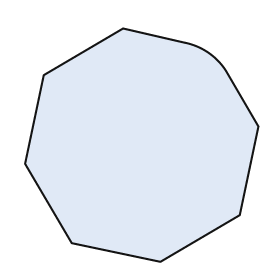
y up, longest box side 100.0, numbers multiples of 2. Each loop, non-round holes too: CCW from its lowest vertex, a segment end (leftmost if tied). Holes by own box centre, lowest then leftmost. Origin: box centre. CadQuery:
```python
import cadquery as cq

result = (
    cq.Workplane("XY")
    .moveTo(8.0, -50.0)
    .lineTo(42.0, -30.0)
    .lineTo(50.0, 8.0)
    .lineTo(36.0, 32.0)
    .threePointArc((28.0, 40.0), (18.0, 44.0))
    .lineTo(-8.0, 50.0)
    .lineTo(-42.0, 30.0)
    .lineTo(-50.0, -8.0)
    .lineTo(-30.0, -42.0)
    .close()
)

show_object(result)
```